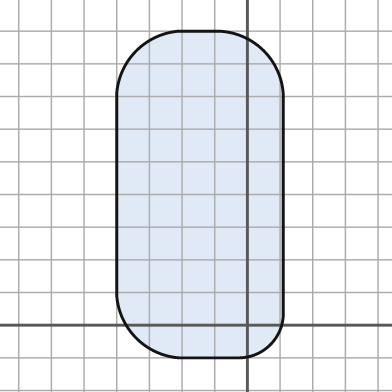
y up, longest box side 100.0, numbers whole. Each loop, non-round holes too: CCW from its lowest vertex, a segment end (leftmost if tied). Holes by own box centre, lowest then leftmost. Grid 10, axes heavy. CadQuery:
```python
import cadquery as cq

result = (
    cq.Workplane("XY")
    .moveTo(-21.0, -10.0)
    .lineTo(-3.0, -10.0)
    .threePointArc((7.0, -6.0), (11.0, 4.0))
    .lineTo(11.0, 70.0)
    .threePointArc((5.0, 84.0), (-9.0, 90.0))
    .lineTo(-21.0, 90.0)
    .threePointArc((-34.0, 84.0), (-40.0, 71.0))
    .lineTo(-40.0, 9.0)
    .threePointArc((-34.0, -4.0), (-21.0, -10.0))
    .close()
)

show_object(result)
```